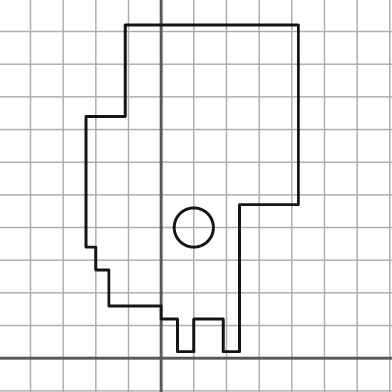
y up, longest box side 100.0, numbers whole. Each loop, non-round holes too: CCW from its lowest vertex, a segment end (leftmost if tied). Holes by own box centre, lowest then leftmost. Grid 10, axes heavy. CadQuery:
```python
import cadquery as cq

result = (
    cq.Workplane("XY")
    .moveTo(5.0, 2.0)
    .lineTo(10.0, 2.0)
    .lineTo(10.0, 12.0)
    .lineTo(19.0, 12.0)
    .lineTo(19.0, 2.0)
    .lineTo(24.0, 2.0)
    .lineTo(24.0, 47.0)
    .lineTo(42.0, 47.0)
    .lineTo(42.0, 102.0)
    .lineTo(-11.0, 102.0)
    .lineTo(-11.0, 74.0)
    .lineTo(-23.0, 74.0)
    .lineTo(-23.0, 34.0)
    .lineTo(-20.0, 34.0)
    .lineTo(-20.0, 27.0)
    .lineTo(-16.0, 27.0)
    .lineTo(-16.0, 16.0)
    .lineTo(0.0, 16.0)
    .lineTo(0.0, 12.0)
    .lineTo(5.0, 12.0)
    .close()
    .moveTo(10.0, 40.0)
    .circle(6.0)
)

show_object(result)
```